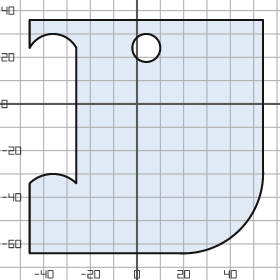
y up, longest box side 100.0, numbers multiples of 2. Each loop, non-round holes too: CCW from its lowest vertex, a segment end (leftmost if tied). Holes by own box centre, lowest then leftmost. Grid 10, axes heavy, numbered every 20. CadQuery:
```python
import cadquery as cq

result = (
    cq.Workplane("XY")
    .moveTo(-46.0, -64.0)
    .lineTo(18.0, -64.0)
    .threePointArc((44.0, -54.0), (54.0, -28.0))
    .lineTo(54.0, 36.0)
    .lineTo(-46.0, 36.0)
    .lineTo(-46.0, 24.0)
    .threePointArc((-36.0, 30.0), (-26.0, 24.0))
    .lineTo(-26.0, -34.0)
    .threePointArc((-36.0, -30.0), (-46.0, -34.0))
    .close()
    .moveTo(4.0, 24.0)
    .circle(6.0)
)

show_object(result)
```